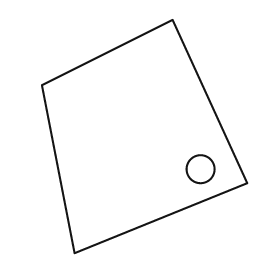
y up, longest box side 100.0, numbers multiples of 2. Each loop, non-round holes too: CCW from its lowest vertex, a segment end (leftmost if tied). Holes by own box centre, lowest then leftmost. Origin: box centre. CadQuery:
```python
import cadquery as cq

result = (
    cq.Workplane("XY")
    .moveTo(-30.0, -50.0)
    .lineTo(44.0, -20.0)
    .lineTo(12.0, 50.0)
    .lineTo(-44.0, 22.0)
    .close()
    .moveTo(24.0, -14.0)
    .circle(6.0)
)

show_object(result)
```